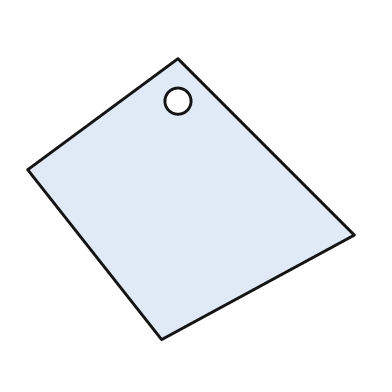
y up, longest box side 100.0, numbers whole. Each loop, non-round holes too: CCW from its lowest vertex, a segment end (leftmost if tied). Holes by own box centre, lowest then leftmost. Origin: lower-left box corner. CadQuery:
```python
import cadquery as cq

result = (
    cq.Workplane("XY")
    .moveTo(41.0, 0.0)
    .lineTo(100.0, 32.0)
    .lineTo(46.0, 86.0)
    .lineTo(0.0, 52.0)
    .close()
    .moveTo(46.0, 73.0)
    .circle(4.0)
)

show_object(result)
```